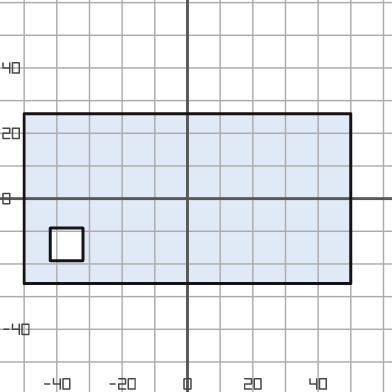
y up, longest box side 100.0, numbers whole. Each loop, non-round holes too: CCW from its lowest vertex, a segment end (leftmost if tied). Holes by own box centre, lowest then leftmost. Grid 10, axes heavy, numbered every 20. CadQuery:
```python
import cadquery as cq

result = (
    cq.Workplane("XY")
    .moveTo(-50.0, -26.0)
    .lineTo(50.0, -26.0)
    .lineTo(50.0, 26.0)
    .lineTo(-50.0, 26.0)
    .close()
    .moveTo(-42.0, -19.0)
    .lineTo(-32.0, -19.0)
    .lineTo(-32.0, -9.0)
    .lineTo(-42.0, -9.0)
    .close()
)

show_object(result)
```